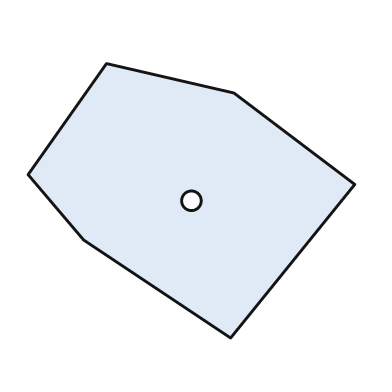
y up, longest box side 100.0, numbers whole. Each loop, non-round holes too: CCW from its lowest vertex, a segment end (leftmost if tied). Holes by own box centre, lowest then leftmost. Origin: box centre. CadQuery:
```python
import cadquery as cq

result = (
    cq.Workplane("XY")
    .moveTo(12.0, -42.0)
    .lineTo(50.0, 5.0)
    .lineTo(13.0, 33.0)
    .lineTo(-26.0, 42.0)
    .lineTo(-50.0, 8.0)
    .lineTo(-33.0, -12.0)
    .close()
    .moveTo(0.0, 0.0)
    .circle(3.0)
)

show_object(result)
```